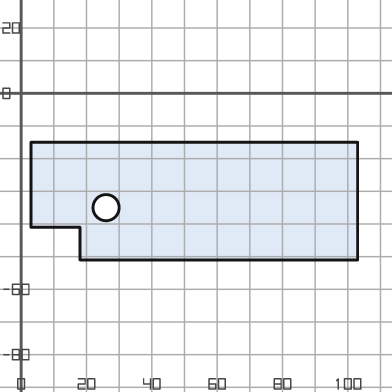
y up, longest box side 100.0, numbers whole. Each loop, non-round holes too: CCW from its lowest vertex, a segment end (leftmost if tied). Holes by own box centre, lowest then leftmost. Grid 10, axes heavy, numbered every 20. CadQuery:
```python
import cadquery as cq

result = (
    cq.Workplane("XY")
    .moveTo(18.0, -51.0)
    .lineTo(103.0, -51.0)
    .lineTo(103.0, -15.0)
    .lineTo(3.0, -15.0)
    .lineTo(3.0, -41.0)
    .lineTo(18.0, -41.0)
    .close()
    .moveTo(26.0, -35.0)
    .circle(4.0)
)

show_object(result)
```